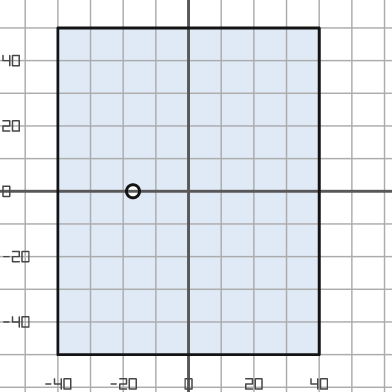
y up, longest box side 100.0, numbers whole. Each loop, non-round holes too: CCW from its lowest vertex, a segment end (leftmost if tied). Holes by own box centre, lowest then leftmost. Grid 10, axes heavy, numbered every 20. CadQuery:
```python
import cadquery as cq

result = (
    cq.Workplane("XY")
    .moveTo(-40.0, -50.0)
    .lineTo(40.0, -50.0)
    .lineTo(40.0, 50.0)
    .lineTo(-40.0, 50.0)
    .close()
    .moveTo(-17.0, 0.0)
    .circle(2.0)
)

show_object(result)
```